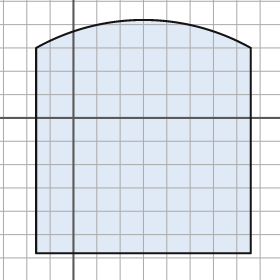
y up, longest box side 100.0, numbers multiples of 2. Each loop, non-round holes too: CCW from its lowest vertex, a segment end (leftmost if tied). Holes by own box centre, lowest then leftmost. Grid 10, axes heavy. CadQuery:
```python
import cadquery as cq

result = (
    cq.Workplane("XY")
    .moveTo(-16.0, -58.0)
    .lineTo(76.0, -58.0)
    .lineTo(76.0, 30.0)
    .threePointArc((30.0, 42.0), (-16.0, 30.0))
    .close()
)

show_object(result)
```